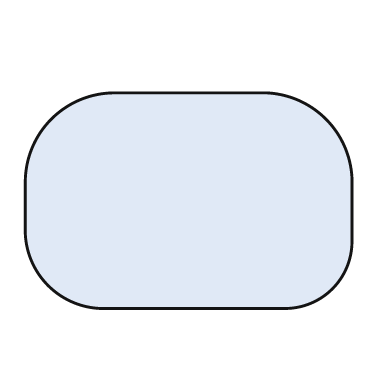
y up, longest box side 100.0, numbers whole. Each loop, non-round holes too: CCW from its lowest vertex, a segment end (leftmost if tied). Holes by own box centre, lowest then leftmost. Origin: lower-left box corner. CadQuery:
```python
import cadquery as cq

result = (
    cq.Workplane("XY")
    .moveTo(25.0, 0.0)
    .lineTo(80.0, 0.0)
    .threePointArc((94.0, 6.0), (100.0, 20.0))
    .lineTo(100.0, 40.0)
    .threePointArc((92.0, 58.0), (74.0, 66.0))
    .lineTo(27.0, 66.0)
    .threePointArc((8.0, 58.0), (0.0, 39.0))
    .lineTo(0.0, 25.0)
    .threePointArc((7.0, 7.0), (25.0, 0.0))
    .close()
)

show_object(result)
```